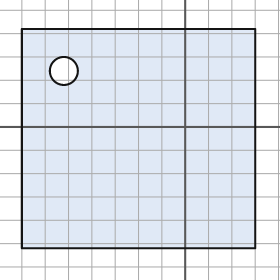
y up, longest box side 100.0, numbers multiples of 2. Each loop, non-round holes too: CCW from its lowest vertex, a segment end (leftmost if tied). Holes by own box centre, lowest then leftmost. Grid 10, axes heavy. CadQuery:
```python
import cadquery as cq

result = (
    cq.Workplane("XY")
    .moveTo(-70.0, -52.0)
    .lineTo(30.0, -52.0)
    .lineTo(30.0, 42.0)
    .lineTo(-70.0, 42.0)
    .close()
    .moveTo(-52.0, 24.0)
    .circle(6.0)
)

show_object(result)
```